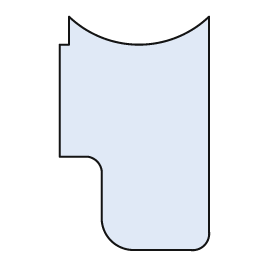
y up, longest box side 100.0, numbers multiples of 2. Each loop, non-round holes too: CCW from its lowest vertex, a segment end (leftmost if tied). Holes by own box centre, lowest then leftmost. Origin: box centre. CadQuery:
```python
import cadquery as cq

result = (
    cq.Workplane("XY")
    .moveTo(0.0, -50.0)
    .lineTo(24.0, -50.0)
    .threePointArc((30.0, -48.0), (32.0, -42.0))
    .lineTo(32.0, 50.0)
    .threePointArc((2.0, 38.0), (-28.0, 50.0))
    .lineTo(-28.0, 38.0)
    .lineTo(-32.0, 38.0)
    .lineTo(-32.0, -10.0)
    .lineTo(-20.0, -10.0)
    .threePointArc((-16.0, -12.0), (-14.0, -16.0))
    .lineTo(-14.0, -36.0)
    .threePointArc((-10.0, -46.0), (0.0, -50.0))
    .close()
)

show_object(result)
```